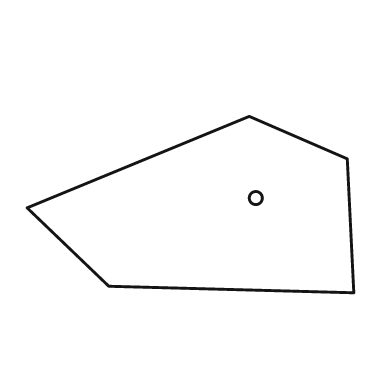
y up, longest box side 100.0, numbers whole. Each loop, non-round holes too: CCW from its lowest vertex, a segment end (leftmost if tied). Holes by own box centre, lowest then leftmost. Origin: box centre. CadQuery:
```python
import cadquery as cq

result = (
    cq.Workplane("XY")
    .moveTo(50.0, -27.0)
    .lineTo(48.0, 14.0)
    .lineTo(18.0, 27.0)
    .lineTo(-50.0, -1.0)
    .lineTo(-25.0, -25.0)
    .close()
    .moveTo(20.0, 2.0)
    .circle(2.0)
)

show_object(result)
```